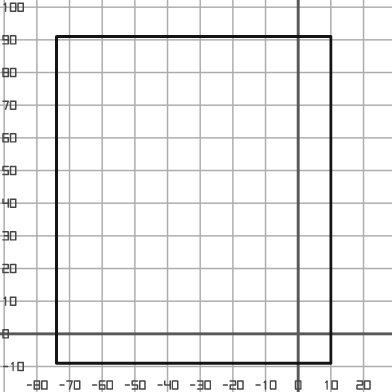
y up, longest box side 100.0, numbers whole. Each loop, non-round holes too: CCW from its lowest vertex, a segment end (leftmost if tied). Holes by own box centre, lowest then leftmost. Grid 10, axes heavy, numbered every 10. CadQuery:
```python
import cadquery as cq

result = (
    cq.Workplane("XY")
    .moveTo(-74.0, -9.0)
    .lineTo(10.0, -9.0)
    .lineTo(10.0, 91.0)
    .lineTo(-74.0, 91.0)
    .close()
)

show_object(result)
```